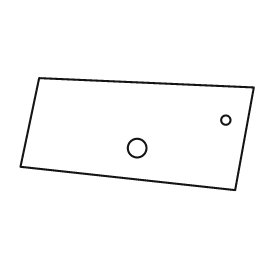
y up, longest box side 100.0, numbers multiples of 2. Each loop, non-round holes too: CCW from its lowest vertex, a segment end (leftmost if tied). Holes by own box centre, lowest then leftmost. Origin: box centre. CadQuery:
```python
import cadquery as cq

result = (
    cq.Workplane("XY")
    .moveTo(42.0, -24.0)
    .lineTo(50.0, 20.0)
    .lineTo(-42.0, 24.0)
    .lineTo(-50.0, -14.0)
    .close()
    .moveTo(0.0, -6.0)
    .circle(4.0)
    .moveTo(38.0, 6.0)
    .circle(2.0)
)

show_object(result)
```